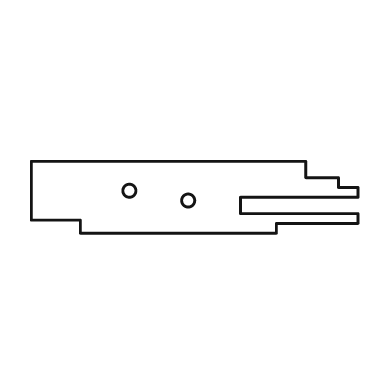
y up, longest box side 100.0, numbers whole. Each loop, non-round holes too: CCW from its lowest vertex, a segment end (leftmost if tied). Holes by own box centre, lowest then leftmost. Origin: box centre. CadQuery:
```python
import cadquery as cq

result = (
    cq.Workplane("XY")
    .moveTo(-35.0, -11.0)
    .lineTo(25.0, -11.0)
    .lineTo(25.0, -8.0)
    .lineTo(50.0, -8.0)
    .lineTo(50.0, -5.0)
    .lineTo(14.0, -5.0)
    .lineTo(14.0, 0.0)
    .lineTo(50.0, 0.0)
    .lineTo(50.0, 3.0)
    .lineTo(44.0, 3.0)
    .lineTo(44.0, 6.0)
    .lineTo(34.0, 6.0)
    .lineTo(34.0, 11.0)
    .lineTo(-50.0, 11.0)
    .lineTo(-50.0, -7.0)
    .lineTo(-35.0, -7.0)
    .close()
    .moveTo(-2.0, -1.0)
    .circle(2.0)
    .moveTo(-20.0, 2.0)
    .circle(2.0)
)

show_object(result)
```